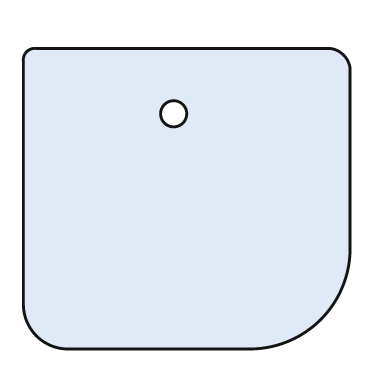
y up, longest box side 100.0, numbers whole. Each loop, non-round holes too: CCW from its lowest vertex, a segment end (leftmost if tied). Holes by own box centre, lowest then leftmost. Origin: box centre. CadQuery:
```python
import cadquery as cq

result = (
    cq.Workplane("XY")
    .moveTo(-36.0, -46.0)
    .lineTo(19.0, -46.0)
    .threePointArc((41.0, -37.0), (50.0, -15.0))
    .lineTo(50.0, 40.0)
    .threePointArc((48.0, 44.0), (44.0, 46.0))
    .lineTo(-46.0, 46.0)
    .threePointArc((-49.0, 45.0), (-50.0, 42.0))
    .lineTo(-50.0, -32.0)
    .threePointArc((-46.0, -42.0), (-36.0, -46.0))
    .close()
    .moveTo(-4.0, 26.0)
    .circle(4.0)
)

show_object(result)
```